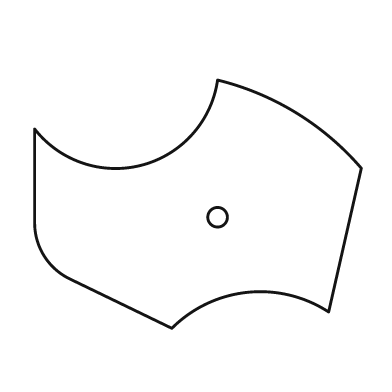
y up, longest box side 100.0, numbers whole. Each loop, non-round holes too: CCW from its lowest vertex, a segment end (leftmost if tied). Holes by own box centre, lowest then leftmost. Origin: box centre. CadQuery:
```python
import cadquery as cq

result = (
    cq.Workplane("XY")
    .moveTo(-8.0, -38.0)
    .threePointArc((15.0, -27.0), (40.0, -33.0))
    .lineTo(50.0, 11.0)
    .threePointArc((30.0, 28.0), (6.0, 38.0))
    .threePointArc((-17.0, 12.0), (-50.0, 23.0))
    .lineTo(-50.0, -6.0)
    .threePointArc((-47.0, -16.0), (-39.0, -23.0))
    .close()
    .moveTo(6.0, -4.0)
    .circle(3.0)
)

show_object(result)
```